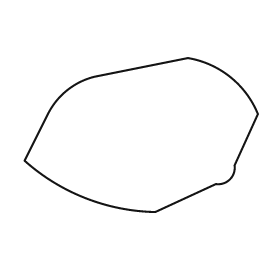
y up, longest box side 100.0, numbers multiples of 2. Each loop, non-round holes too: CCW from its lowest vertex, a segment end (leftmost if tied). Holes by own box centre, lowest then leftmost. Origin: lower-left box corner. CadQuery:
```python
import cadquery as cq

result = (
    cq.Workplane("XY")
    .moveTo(56.0, 0.0)
    .lineTo(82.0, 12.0)
    .threePointArc((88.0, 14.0), (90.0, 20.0))
    .lineTo(100.0, 42.0)
    .threePointArc((88.0, 58.0), (70.0, 66.0))
    .lineTo(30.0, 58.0)
    .threePointArc((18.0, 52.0), (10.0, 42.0))
    .lineTo(0.0, 22.0)
    .threePointArc((26.0, 6.0), (56.0, 0.0))
    .close()
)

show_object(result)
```